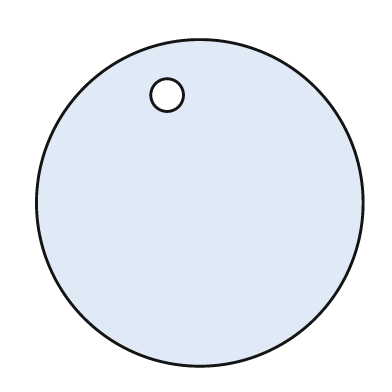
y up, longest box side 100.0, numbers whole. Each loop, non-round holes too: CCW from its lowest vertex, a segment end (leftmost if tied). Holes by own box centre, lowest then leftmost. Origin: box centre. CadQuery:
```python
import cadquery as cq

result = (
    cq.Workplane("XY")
    .moveTo(0.0, 0.0)
    .circle(50.0)
    .moveTo(-10.0, 33.0)
    .circle(5.0)
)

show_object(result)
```